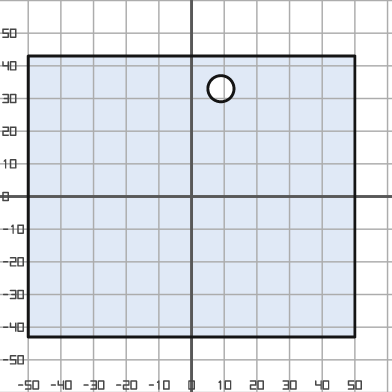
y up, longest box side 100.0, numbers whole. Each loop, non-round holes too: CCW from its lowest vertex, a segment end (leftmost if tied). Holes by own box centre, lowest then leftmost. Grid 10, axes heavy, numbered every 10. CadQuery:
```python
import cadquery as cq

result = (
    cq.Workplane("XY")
    .moveTo(-50.0, -43.0)
    .lineTo(50.0, -43.0)
    .lineTo(50.0, 43.0)
    .lineTo(-50.0, 43.0)
    .close()
    .moveTo(9.0, 33.0)
    .circle(4.0)
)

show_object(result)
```